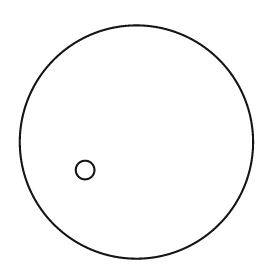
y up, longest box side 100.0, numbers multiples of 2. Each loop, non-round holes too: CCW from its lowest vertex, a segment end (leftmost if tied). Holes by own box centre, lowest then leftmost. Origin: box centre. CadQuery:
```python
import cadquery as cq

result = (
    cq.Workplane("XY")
    .moveTo(0.0, 0.0)
    .circle(50.0)
    .moveTo(-22.0, -12.0)
    .circle(4.0)
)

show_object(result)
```